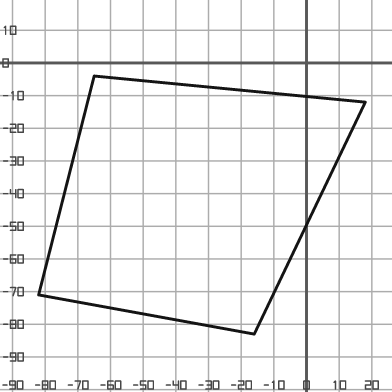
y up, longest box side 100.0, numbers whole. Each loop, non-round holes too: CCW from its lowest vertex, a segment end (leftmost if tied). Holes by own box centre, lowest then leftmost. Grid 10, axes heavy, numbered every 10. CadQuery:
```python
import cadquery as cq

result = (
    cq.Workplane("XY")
    .moveTo(-16.0, -83.0)
    .lineTo(18.0, -12.0)
    .lineTo(-65.0, -4.0)
    .lineTo(-82.0, -71.0)
    .close()
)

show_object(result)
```